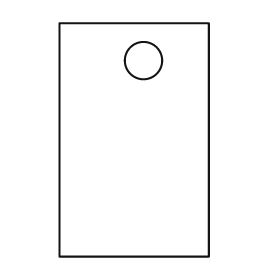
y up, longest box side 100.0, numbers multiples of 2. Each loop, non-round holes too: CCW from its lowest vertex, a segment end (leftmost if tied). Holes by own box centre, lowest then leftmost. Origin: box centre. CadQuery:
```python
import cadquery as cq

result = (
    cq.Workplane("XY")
    .moveTo(-32.0, -50.0)
    .lineTo(32.0, -50.0)
    .lineTo(32.0, 50.0)
    .lineTo(-32.0, 50.0)
    .close()
    .moveTo(4.0, 34.0)
    .circle(8.0)
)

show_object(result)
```